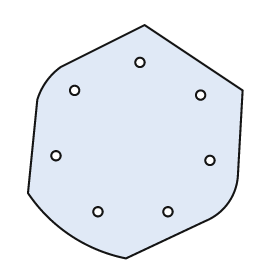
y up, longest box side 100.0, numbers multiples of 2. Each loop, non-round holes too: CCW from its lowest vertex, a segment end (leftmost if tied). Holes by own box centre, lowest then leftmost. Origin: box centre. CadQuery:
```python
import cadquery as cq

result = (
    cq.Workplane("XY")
    .moveTo(-4.0, -50.0)
    .lineTo(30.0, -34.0)
    .threePointArc((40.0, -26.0), (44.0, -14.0))
    .lineTo(46.0, 22.0)
    .lineTo(4.0, 50.0)
    .lineTo(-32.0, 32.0)
    .threePointArc((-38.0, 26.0), (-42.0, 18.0))
    .lineTo(-46.0, -22.0)
    .threePointArc((-28.0, -40.0), (-4.0, -50.0))
    .close()
    .moveTo(-16.0, -30.0)
    .circle(2.0)
    .moveTo(14.0, -30.0)
    .circle(2.0)
    .moveTo(32.0, -8.0)
    .circle(2.0)
    .moveTo(-34.0, -6.0)
    .circle(2.0)
    .moveTo(28.0, 20.0)
    .circle(2.0)
    .moveTo(-26.0, 22.0)
    .circle(2.0)
    .moveTo(2.0, 34.0)
    .circle(2.0)
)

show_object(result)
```